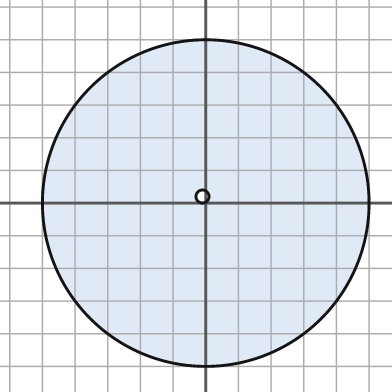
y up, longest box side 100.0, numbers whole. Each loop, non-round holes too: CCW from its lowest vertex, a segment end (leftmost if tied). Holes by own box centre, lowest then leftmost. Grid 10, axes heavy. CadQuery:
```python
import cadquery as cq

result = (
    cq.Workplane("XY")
    .moveTo(0.0, 0.0)
    .circle(50.0)
    .moveTo(-1.0, 2.0)
    .circle(2.0)
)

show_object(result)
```